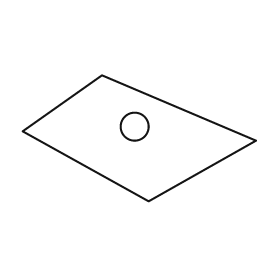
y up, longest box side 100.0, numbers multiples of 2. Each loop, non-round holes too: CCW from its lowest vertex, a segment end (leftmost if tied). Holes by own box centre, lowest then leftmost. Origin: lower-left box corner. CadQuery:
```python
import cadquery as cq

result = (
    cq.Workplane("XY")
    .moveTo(54.0, 0.0)
    .lineTo(100.0, 26.0)
    .lineTo(34.0, 54.0)
    .lineTo(0.0, 30.0)
    .close()
    .moveTo(48.0, 32.0)
    .circle(6.0)
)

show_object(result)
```